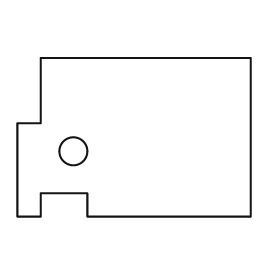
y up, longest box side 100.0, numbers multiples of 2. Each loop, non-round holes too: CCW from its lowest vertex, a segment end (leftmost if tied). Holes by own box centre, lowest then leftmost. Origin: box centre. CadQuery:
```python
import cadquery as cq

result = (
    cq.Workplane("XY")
    .moveTo(-50.0, -34.0)
    .lineTo(-40.0, -34.0)
    .lineTo(-40.0, -24.0)
    .lineTo(-20.0, -24.0)
    .lineTo(-20.0, -34.0)
    .lineTo(50.0, -34.0)
    .lineTo(50.0, 34.0)
    .lineTo(-40.0, 34.0)
    .lineTo(-40.0, 6.0)
    .lineTo(-50.0, 6.0)
    .close()
    .moveTo(-26.0, -6.0)
    .circle(6.0)
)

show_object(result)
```